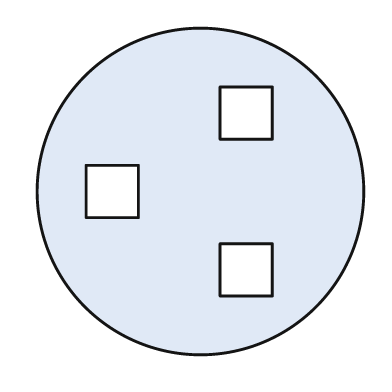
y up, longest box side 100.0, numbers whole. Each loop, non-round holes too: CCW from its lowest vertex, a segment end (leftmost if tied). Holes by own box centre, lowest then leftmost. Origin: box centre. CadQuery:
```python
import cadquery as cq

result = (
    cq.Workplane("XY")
    .moveTo(0.0, 0.0)
    .circle(50.0)
    .moveTo(6.0, -32.0)
    .lineTo(22.0, -32.0)
    .lineTo(22.0, -16.0)
    .lineTo(6.0, -16.0)
    .close()
    .moveTo(-35.0, -8.0)
    .lineTo(-19.0, -8.0)
    .lineTo(-19.0, 8.0)
    .lineTo(-35.0, 8.0)
    .close()
    .moveTo(6.0, 16.0)
    .lineTo(22.0, 16.0)
    .lineTo(22.0, 32.0)
    .lineTo(6.0, 32.0)
    .close()
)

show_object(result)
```